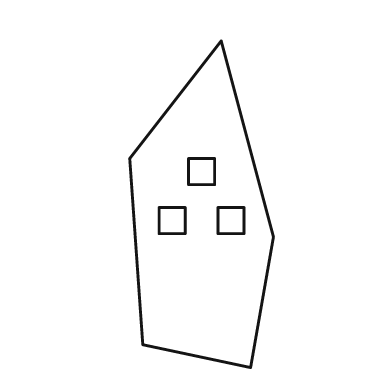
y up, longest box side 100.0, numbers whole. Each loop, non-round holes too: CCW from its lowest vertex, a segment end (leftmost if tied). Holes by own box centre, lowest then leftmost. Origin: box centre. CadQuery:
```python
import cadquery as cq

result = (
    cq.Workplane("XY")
    .moveTo(15.0, -50.0)
    .lineTo(22.0, -10.0)
    .lineTo(6.0, 50.0)
    .lineTo(-22.0, 14.0)
    .lineTo(-18.0, -43.0)
    .close()
    .moveTo(-13.0, -9.0)
    .lineTo(-5.0, -9.0)
    .lineTo(-5.0, -1.0)
    .lineTo(-13.0, -1.0)
    .close()
    .moveTo(5.0, -9.0)
    .lineTo(13.0, -9.0)
    .lineTo(13.0, -1.0)
    .lineTo(5.0, -1.0)
    .close()
    .moveTo(-4.0, 6.0)
    .lineTo(4.0, 6.0)
    .lineTo(4.0, 14.0)
    .lineTo(-4.0, 14.0)
    .close()
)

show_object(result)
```